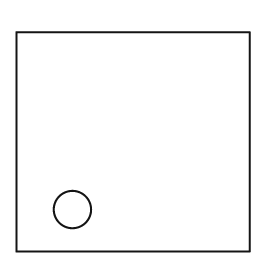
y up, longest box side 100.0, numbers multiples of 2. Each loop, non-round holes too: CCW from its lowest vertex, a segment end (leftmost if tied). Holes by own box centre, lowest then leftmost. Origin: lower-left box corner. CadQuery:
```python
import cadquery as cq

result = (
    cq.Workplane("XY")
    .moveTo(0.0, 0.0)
    .lineTo(100.0, 0.0)
    .lineTo(100.0, 94.0)
    .lineTo(0.0, 94.0)
    .close()
    .moveTo(24.0, 18.0)
    .circle(8.0)
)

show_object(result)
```